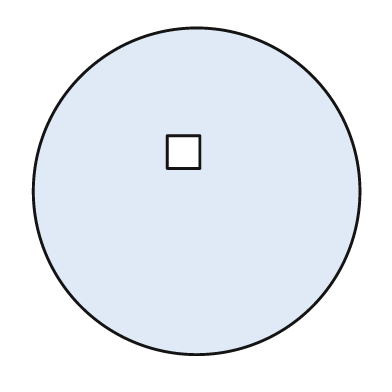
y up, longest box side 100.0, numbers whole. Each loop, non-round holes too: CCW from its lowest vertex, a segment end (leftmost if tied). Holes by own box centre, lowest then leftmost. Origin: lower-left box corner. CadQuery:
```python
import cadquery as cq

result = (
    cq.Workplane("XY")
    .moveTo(50.0, 50.0)
    .circle(50.0)
    .moveTo(41.0, 57.0)
    .lineTo(51.0, 57.0)
    .lineTo(51.0, 67.0)
    .lineTo(41.0, 67.0)
    .close()
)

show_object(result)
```